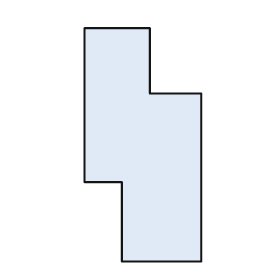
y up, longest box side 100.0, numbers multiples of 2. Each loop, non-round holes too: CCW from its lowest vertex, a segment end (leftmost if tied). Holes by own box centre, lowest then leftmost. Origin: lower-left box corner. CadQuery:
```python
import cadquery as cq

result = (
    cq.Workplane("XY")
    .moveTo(16.0, 0.0)
    .lineTo(50.0, 0.0)
    .lineTo(50.0, 72.0)
    .lineTo(28.0, 72.0)
    .lineTo(28.0, 100.0)
    .lineTo(0.0, 100.0)
    .lineTo(0.0, 34.0)
    .lineTo(16.0, 34.0)
    .close()
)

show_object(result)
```